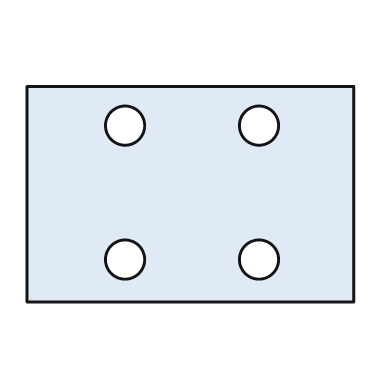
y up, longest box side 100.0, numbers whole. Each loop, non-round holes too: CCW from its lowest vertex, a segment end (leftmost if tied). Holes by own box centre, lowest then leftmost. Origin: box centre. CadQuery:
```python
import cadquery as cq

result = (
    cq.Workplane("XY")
    .moveTo(-50.0, -33.0)
    .lineTo(50.0, -33.0)
    .lineTo(50.0, 33.0)
    .lineTo(-50.0, 33.0)
    .close()
    .moveTo(-20.0, -20.0)
    .circle(6.0)
    .moveTo(21.0, -20.0)
    .circle(6.0)
    .moveTo(-20.0, 21.0)
    .circle(6.0)
    .moveTo(21.0, 21.0)
    .circle(6.0)
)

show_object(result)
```